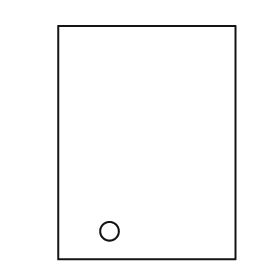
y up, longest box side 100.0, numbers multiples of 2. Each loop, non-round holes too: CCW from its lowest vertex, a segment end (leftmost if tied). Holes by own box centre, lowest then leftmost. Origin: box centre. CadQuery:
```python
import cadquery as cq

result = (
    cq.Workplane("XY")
    .moveTo(-38.0, -50.0)
    .lineTo(38.0, -50.0)
    .lineTo(38.0, 50.0)
    .lineTo(-38.0, 50.0)
    .close()
    .moveTo(-16.0, -38.0)
    .circle(4.0)
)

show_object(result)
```